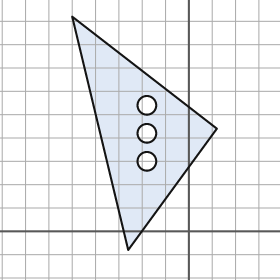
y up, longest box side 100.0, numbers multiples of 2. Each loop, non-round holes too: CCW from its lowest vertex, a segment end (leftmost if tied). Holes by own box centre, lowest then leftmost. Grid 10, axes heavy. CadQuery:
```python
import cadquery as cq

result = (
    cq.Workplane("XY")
    .moveTo(-26.0, -8.0)
    .lineTo(12.0, 44.0)
    .lineTo(-50.0, 92.0)
    .close()
    .moveTo(-18.0, 30.0)
    .circle(4.0)
    .moveTo(-18.0, 42.0)
    .circle(4.0)
    .moveTo(-18.0, 54.0)
    .circle(4.0)
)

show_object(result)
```